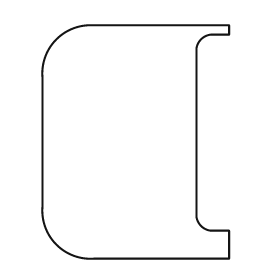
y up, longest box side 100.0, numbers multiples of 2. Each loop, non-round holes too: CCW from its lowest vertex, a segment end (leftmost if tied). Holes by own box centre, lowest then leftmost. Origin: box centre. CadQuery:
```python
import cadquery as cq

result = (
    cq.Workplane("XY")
    .moveTo(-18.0, -50.0)
    .lineTo(40.0, -50.0)
    .lineTo(40.0, -38.0)
    .lineTo(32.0, -38.0)
    .threePointArc((28.0, -36.0), (26.0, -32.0))
    .lineTo(26.0, 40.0)
    .threePointArc((28.0, 44.0), (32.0, 46.0))
    .lineTo(40.0, 46.0)
    .lineTo(40.0, 50.0)
    .lineTo(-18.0, 50.0)
    .threePointArc((-34.0, 44.0), (-40.0, 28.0))
    .lineTo(-40.0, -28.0)
    .threePointArc((-34.0, -44.0), (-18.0, -50.0))
    .close()
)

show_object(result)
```